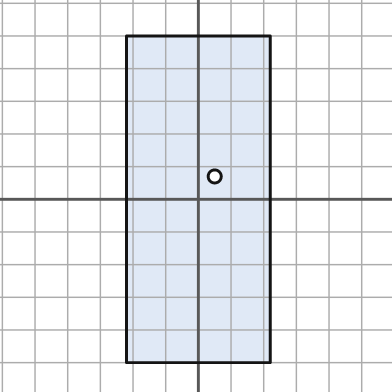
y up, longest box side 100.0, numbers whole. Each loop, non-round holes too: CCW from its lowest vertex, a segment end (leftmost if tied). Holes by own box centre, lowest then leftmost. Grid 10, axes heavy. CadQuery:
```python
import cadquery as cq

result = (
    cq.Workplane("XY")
    .moveTo(-22.0, -50.0)
    .lineTo(22.0, -50.0)
    .lineTo(22.0, 50.0)
    .lineTo(-22.0, 50.0)
    .close()
    .moveTo(5.0, 7.0)
    .circle(2.0)
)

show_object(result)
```